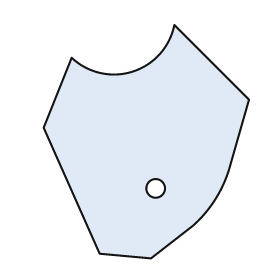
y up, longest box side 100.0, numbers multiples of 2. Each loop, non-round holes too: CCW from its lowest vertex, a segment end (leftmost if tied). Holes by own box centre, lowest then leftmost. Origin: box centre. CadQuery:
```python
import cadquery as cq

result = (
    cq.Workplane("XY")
    .moveTo(2.0, -50.0)
    .lineTo(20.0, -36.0)
    .threePointArc((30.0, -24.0), (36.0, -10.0))
    .lineTo(44.0, 18.0)
    .lineTo(12.0, 50.0)
    .threePointArc((-6.0, 30.0), (-32.0, 36.0))
    .lineTo(-44.0, 6.0)
    .lineTo(-20.0, -48.0)
    .close()
    .moveTo(4.0, -20.0)
    .circle(4.0)
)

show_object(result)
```